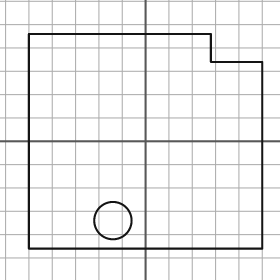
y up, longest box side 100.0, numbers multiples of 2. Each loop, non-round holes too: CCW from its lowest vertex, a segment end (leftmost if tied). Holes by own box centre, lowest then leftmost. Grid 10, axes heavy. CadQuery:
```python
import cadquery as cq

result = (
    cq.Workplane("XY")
    .moveTo(-50.0, -46.0)
    .lineTo(50.0, -46.0)
    .lineTo(50.0, 34.0)
    .lineTo(28.0, 34.0)
    .lineTo(28.0, 46.0)
    .lineTo(-50.0, 46.0)
    .close()
    .moveTo(-14.0, -34.0)
    .circle(8.0)
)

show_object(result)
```